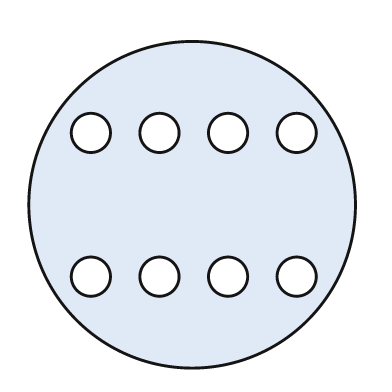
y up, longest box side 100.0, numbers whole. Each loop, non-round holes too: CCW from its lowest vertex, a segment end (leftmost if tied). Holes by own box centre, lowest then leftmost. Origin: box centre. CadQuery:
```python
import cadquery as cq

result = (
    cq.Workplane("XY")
    .moveTo(0.0, 0.0)
    .circle(50.0)
    .moveTo(-31.0, -22.0)
    .circle(6.0)
    .moveTo(-10.0, -22.0)
    .circle(6.0)
    .moveTo(11.0, -22.0)
    .circle(6.0)
    .moveTo(32.0, -22.0)
    .circle(6.0)
    .moveTo(-31.0, 22.0)
    .circle(6.0)
    .moveTo(-10.0, 22.0)
    .circle(6.0)
    .moveTo(11.0, 22.0)
    .circle(6.0)
    .moveTo(32.0, 22.0)
    .circle(6.0)
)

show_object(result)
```